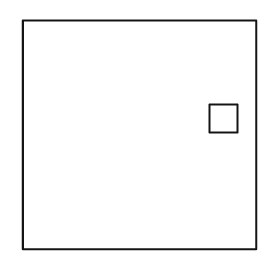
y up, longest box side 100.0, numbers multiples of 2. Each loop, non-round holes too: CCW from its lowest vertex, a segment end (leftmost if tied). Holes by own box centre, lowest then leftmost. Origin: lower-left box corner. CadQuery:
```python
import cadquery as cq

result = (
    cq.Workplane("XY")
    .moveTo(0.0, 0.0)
    .lineTo(100.0, 0.0)
    .lineTo(100.0, 98.0)
    .lineTo(0.0, 98.0)
    .close()
    .moveTo(80.0, 50.0)
    .lineTo(92.0, 50.0)
    .lineTo(92.0, 62.0)
    .lineTo(80.0, 62.0)
    .close()
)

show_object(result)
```